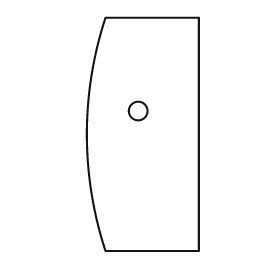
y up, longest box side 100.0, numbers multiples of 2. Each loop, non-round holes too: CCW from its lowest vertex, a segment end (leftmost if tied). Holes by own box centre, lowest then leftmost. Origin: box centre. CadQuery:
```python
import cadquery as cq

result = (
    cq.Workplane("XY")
    .moveTo(-16.0, -50.0)
    .lineTo(24.0, -50.0)
    .lineTo(24.0, 50.0)
    .lineTo(-16.0, 50.0)
    .threePointArc((-24.0, 0.0), (-16.0, -50.0))
    .close()
    .moveTo(-2.0, 10.0)
    .circle(4.0)
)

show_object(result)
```